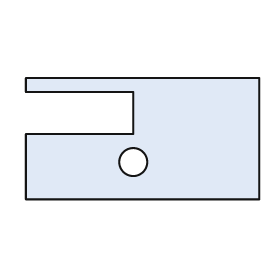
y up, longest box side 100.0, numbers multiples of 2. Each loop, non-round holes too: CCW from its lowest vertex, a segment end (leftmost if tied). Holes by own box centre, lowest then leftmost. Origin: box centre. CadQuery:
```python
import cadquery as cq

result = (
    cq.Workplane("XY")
    .moveTo(-50.0, -26.0)
    .lineTo(50.0, -26.0)
    .lineTo(50.0, 26.0)
    .lineTo(-50.0, 26.0)
    .lineTo(-50.0, 20.0)
    .lineTo(-4.0, 20.0)
    .lineTo(-4.0, 2.0)
    .lineTo(-50.0, 2.0)
    .close()
    .moveTo(-4.0, -10.0)
    .circle(6.0)
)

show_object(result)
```